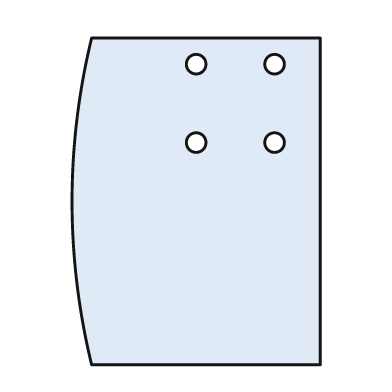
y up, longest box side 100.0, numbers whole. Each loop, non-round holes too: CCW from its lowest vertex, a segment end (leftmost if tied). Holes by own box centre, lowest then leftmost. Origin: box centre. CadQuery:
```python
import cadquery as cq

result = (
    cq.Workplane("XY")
    .moveTo(-32.0, -50.0)
    .lineTo(38.0, -50.0)
    .lineTo(38.0, 50.0)
    .lineTo(-32.0, 50.0)
    .threePointArc((-38.0, 0.0), (-32.0, -50.0))
    .close()
    .moveTo(0.0, 18.0)
    .circle(3.0)
    .moveTo(24.0, 18.0)
    .circle(3.0)
    .moveTo(0.0, 42.0)
    .circle(3.0)
    .moveTo(24.0, 42.0)
    .circle(3.0)
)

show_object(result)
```